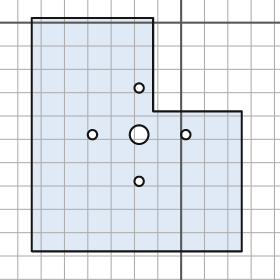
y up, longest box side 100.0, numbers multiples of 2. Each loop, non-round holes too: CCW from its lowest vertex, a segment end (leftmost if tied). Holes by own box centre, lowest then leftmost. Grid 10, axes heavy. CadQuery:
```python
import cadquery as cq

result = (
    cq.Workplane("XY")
    .moveTo(-64.0, -98.0)
    .lineTo(26.0, -98.0)
    .lineTo(26.0, -38.0)
    .lineTo(-12.0, -38.0)
    .lineTo(-12.0, 2.0)
    .lineTo(-64.0, 2.0)
    .close()
    .moveTo(-18.0, -68.0)
    .circle(2.0)
    .moveTo(-38.0, -48.0)
    .circle(2.0)
    .moveTo(-18.0, -48.0)
    .circle(4.0)
    .moveTo(2.0, -48.0)
    .circle(2.0)
    .moveTo(-18.0, -28.0)
    .circle(2.0)
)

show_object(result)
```